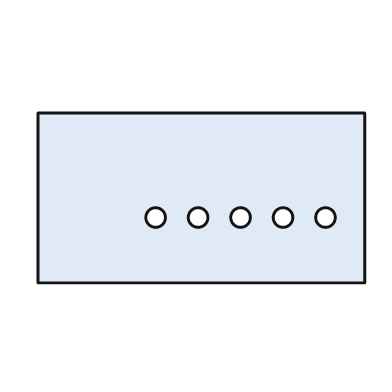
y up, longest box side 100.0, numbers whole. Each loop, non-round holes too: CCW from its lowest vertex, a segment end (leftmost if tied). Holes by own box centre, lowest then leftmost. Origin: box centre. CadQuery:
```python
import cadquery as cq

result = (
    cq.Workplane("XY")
    .moveTo(-50.0, -26.0)
    .lineTo(50.0, -26.0)
    .lineTo(50.0, 26.0)
    .lineTo(-50.0, 26.0)
    .close()
    .moveTo(-14.0, -6.0)
    .circle(3.0)
    .moveTo(-1.0, -6.0)
    .circle(3.0)
    .moveTo(12.0, -6.0)
    .circle(3.0)
    .moveTo(25.0, -6.0)
    .circle(3.0)
    .moveTo(38.0, -6.0)
    .circle(3.0)
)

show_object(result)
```